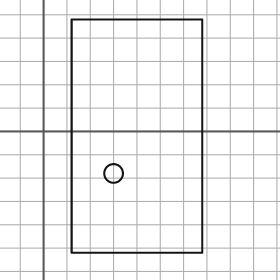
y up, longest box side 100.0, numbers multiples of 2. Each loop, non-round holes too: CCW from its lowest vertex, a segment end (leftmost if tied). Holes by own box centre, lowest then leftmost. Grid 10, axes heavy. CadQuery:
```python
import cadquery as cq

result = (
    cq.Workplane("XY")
    .moveTo(12.0, -52.0)
    .lineTo(68.0, -52.0)
    .lineTo(68.0, 48.0)
    .lineTo(12.0, 48.0)
    .close()
    .moveTo(30.0, -18.0)
    .circle(4.0)
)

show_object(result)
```